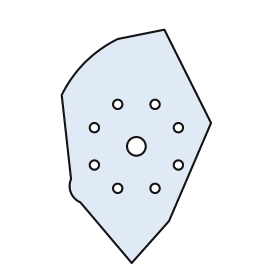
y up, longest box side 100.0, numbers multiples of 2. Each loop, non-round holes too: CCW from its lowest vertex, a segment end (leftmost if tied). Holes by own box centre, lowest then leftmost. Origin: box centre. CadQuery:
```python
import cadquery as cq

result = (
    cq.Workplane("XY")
    .moveTo(-2.0, -50.0)
    .lineTo(14.0, -32.0)
    .lineTo(32.0, 10.0)
    .lineTo(12.0, 50.0)
    .lineTo(-8.0, 46.0)
    .threePointArc((-22.0, 36.0), (-32.0, 22.0))
    .lineTo(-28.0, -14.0)
    .threePointArc((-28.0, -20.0), (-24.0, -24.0))
    .close()
    .moveTo(-8.0, -18.0)
    .circle(2.0)
    .moveTo(8.0, -18.0)
    .circle(2.0)
    .moveTo(-18.0, -8.0)
    .circle(2.0)
    .moveTo(18.0, -8.0)
    .circle(2.0)
    .moveTo(0.0, 0.0)
    .circle(4.0)
    .moveTo(-18.0, 8.0)
    .circle(2.0)
    .moveTo(18.0, 8.0)
    .circle(2.0)
    .moveTo(-8.0, 18.0)
    .circle(2.0)
    .moveTo(8.0, 18.0)
    .circle(2.0)
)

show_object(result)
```